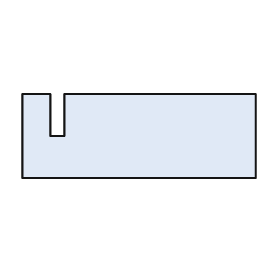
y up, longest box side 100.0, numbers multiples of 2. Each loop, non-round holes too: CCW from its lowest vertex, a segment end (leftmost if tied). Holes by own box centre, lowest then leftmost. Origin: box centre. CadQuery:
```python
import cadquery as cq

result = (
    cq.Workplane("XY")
    .moveTo(-50.0, -18.0)
    .lineTo(50.0, -18.0)
    .lineTo(50.0, 18.0)
    .lineTo(-32.0, 18.0)
    .lineTo(-32.0, 0.0)
    .lineTo(-38.0, 0.0)
    .lineTo(-38.0, 18.0)
    .lineTo(-50.0, 18.0)
    .close()
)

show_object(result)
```